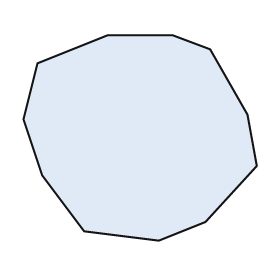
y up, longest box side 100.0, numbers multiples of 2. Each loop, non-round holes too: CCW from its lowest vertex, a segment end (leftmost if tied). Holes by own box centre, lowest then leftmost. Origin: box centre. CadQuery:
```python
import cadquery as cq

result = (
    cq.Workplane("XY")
    .moveTo(8.0, -44.0)
    .lineTo(28.0, -36.0)
    .lineTo(50.0, -12.0)
    .lineTo(46.0, 10.0)
    .lineTo(30.0, 38.0)
    .lineTo(14.0, 44.0)
    .lineTo(-14.0, 44.0)
    .lineTo(-44.0, 32.0)
    .lineTo(-50.0, 8.0)
    .lineTo(-42.0, -16.0)
    .lineTo(-24.0, -40.0)
    .close()
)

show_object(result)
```